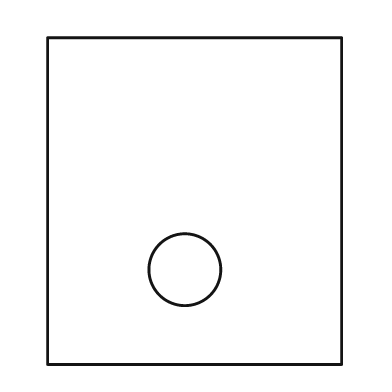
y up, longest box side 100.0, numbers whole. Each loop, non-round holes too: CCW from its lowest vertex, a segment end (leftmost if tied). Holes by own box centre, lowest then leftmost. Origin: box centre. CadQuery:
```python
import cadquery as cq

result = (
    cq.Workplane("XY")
    .moveTo(-45.0, -50.0)
    .lineTo(45.0, -50.0)
    .lineTo(45.0, 50.0)
    .lineTo(-45.0, 50.0)
    .close()
    .moveTo(-3.0, -21.0)
    .circle(11.0)
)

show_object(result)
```